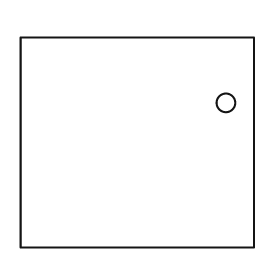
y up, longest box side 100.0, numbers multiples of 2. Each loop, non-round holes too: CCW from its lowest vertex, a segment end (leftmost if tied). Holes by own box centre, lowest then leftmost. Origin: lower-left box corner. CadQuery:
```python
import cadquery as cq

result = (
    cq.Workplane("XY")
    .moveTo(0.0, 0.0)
    .lineTo(100.0, 0.0)
    .lineTo(100.0, 90.0)
    .lineTo(0.0, 90.0)
    .close()
    .moveTo(88.0, 62.0)
    .circle(4.0)
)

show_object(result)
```